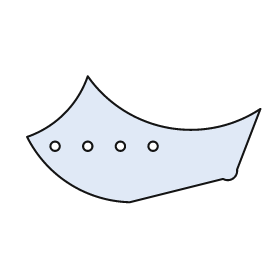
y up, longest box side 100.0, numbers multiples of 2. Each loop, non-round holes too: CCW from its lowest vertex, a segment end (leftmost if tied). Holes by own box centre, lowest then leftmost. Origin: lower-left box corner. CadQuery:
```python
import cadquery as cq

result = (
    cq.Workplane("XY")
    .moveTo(44.0, 0.0)
    .lineTo(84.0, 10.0)
    .threePointArc((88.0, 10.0), (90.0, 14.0))
    .lineTo(100.0, 40.0)
    .threePointArc((60.0, 32.0), (26.0, 54.0))
    .threePointArc((16.0, 38.0), (0.0, 28.0))
    .threePointArc((18.0, 8.0), (44.0, 0.0))
    .close()
    .moveTo(12.0, 24.0)
    .circle(2.0)
    .moveTo(26.0, 24.0)
    .circle(2.0)
    .moveTo(40.0, 24.0)
    .circle(2.0)
    .moveTo(54.0, 24.0)
    .circle(2.0)
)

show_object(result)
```